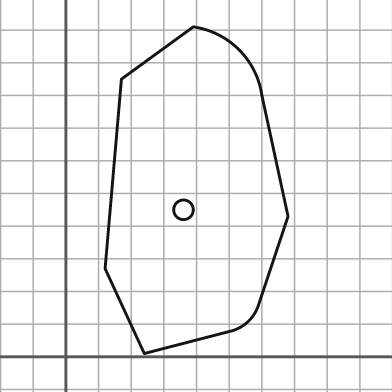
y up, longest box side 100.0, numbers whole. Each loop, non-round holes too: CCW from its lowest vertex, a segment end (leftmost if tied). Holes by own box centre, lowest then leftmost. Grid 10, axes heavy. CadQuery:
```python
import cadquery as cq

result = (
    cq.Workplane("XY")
    .moveTo(24.0, 1.0)
    .lineTo(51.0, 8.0)
    .threePointArc((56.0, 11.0), (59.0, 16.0))
    .lineTo(68.0, 43.0)
    .lineTo(60.0, 80.0)
    .threePointArc((53.0, 94.0), (39.0, 101.0))
    .lineTo(17.0, 85.0)
    .lineTo(12.0, 27.0)
    .close()
    .moveTo(36.0, 45.0)
    .circle(3.0)
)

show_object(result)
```